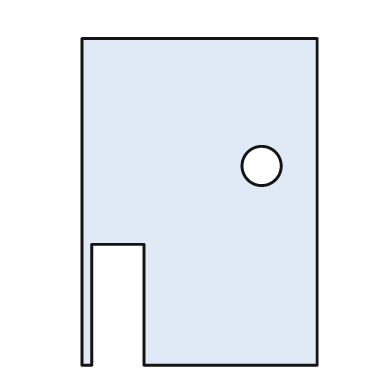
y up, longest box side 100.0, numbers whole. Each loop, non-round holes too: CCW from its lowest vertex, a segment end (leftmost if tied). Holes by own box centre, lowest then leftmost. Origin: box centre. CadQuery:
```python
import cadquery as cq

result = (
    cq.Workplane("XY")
    .moveTo(-36.0, -50.0)
    .lineTo(-33.0, -50.0)
    .lineTo(-33.0, -13.0)
    .lineTo(-17.0, -13.0)
    .lineTo(-17.0, -50.0)
    .lineTo(36.0, -50.0)
    .lineTo(36.0, 50.0)
    .lineTo(-36.0, 50.0)
    .close()
    .moveTo(19.0, 11.0)
    .circle(6.0)
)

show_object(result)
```